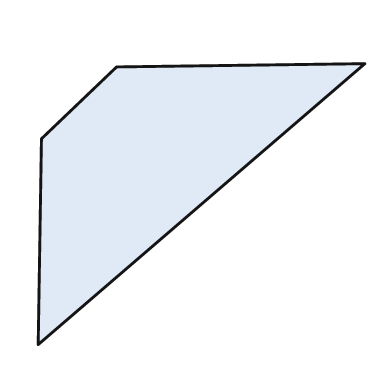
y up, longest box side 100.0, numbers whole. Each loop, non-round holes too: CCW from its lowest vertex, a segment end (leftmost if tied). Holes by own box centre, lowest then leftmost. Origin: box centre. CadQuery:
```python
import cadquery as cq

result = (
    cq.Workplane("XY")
    .moveTo(-50.0, -43.0)
    .lineTo(50.0, 43.0)
    .lineTo(-26.0, 42.0)
    .lineTo(-49.0, 20.0)
    .close()
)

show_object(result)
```